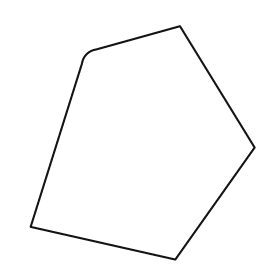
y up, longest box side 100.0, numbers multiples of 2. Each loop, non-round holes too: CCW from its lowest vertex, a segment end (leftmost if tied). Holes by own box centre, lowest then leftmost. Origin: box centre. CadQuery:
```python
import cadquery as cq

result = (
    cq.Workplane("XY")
    .moveTo(14.0, -50.0)
    .lineTo(48.0, -2.0)
    .lineTo(16.0, 50.0)
    .lineTo(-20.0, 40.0)
    .threePointArc((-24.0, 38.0), (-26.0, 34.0))
    .lineTo(-48.0, -36.0)
    .close()
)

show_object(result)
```